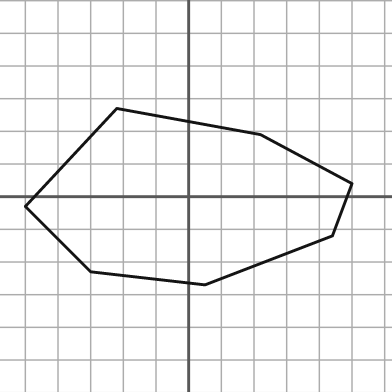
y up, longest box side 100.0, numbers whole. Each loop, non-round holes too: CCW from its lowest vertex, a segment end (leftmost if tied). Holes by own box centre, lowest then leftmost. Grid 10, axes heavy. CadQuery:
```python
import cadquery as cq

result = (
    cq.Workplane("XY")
    .moveTo(5.0, -27.0)
    .lineTo(44.0, -12.0)
    .lineTo(50.0, 4.0)
    .lineTo(22.0, 19.0)
    .lineTo(-22.0, 27.0)
    .lineTo(-50.0, -3.0)
    .lineTo(-30.0, -23.0)
    .close()
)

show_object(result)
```